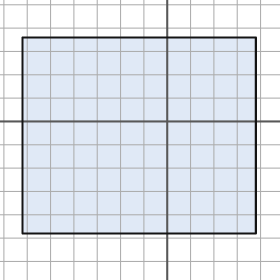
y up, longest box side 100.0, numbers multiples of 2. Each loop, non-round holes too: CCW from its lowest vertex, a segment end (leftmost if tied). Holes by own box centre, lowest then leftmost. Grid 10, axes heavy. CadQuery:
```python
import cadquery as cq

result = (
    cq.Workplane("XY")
    .moveTo(-62.0, -48.0)
    .lineTo(38.0, -48.0)
    .lineTo(38.0, 36.0)
    .lineTo(-62.0, 36.0)
    .close()
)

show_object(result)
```